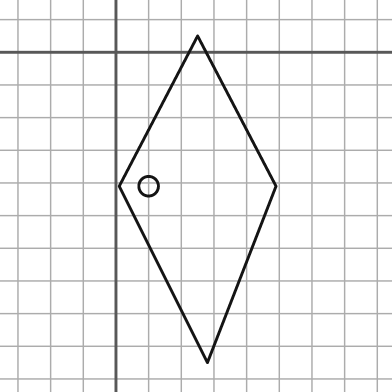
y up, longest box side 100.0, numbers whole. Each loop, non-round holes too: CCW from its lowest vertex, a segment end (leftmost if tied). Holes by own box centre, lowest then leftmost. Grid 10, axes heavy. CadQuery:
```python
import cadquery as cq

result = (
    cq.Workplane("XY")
    .moveTo(28.0, -95.0)
    .lineTo(49.0, -41.0)
    .lineTo(25.0, 5.0)
    .lineTo(1.0, -41.0)
    .close()
    .moveTo(10.0, -41.0)
    .circle(3.0)
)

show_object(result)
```